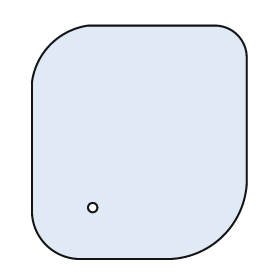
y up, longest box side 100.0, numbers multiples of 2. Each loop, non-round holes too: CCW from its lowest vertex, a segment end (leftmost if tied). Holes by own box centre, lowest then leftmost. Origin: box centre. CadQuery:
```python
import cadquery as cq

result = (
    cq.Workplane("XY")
    .moveTo(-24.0, -50.0)
    .lineTo(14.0, -50.0)
    .threePointArc((36.0, -40.0), (46.0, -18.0))
    .lineTo(46.0, 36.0)
    .threePointArc((42.0, 46.0), (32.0, 50.0))
    .lineTo(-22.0, 50.0)
    .threePointArc((-38.0, 42.0), (-46.0, 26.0))
    .lineTo(-46.0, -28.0)
    .threePointArc((-40.0, -44.0), (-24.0, -50.0))
    .close()
    .moveTo(-20.0, -28.0)
    .circle(2.0)
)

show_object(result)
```